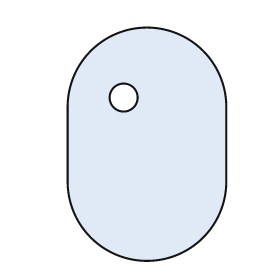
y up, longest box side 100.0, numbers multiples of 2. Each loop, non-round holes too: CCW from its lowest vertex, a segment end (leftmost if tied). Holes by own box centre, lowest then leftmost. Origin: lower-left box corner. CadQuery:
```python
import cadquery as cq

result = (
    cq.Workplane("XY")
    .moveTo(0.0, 34.0)
    .threePointArc((34.0, 0.0), (68.0, 34.0))
    .lineTo(68.0, 66.0)
    .threePointArc((34.0, 100.0), (0.0, 66.0))
    .close()
    .moveTo(24.0, 70.0)
    .circle(6.0)
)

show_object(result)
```